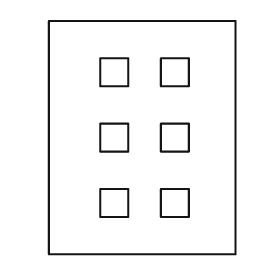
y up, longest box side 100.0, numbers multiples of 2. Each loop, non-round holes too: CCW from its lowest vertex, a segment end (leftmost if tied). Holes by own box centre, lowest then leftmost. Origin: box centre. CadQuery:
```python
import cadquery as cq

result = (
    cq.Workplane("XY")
    .moveTo(-40.0, -50.0)
    .lineTo(40.0, -50.0)
    .lineTo(40.0, 50.0)
    .lineTo(-40.0, 50.0)
    .close()
    .moveTo(-18.0, -34.0)
    .lineTo(-6.0, -34.0)
    .lineTo(-6.0, -22.0)
    .lineTo(-18.0, -22.0)
    .close()
    .moveTo(8.0, -34.0)
    .lineTo(20.0, -34.0)
    .lineTo(20.0, -22.0)
    .lineTo(8.0, -22.0)
    .close()
    .moveTo(-18.0, -6.0)
    .lineTo(-6.0, -6.0)
    .lineTo(-6.0, 6.0)
    .lineTo(-18.0, 6.0)
    .close()
    .moveTo(8.0, -6.0)
    .lineTo(20.0, -6.0)
    .lineTo(20.0, 6.0)
    .lineTo(8.0, 6.0)
    .close()
    .moveTo(-18.0, 22.0)
    .lineTo(-6.0, 22.0)
    .lineTo(-6.0, 34.0)
    .lineTo(-18.0, 34.0)
    .close()
    .moveTo(8.0, 22.0)
    .lineTo(20.0, 22.0)
    .lineTo(20.0, 34.0)
    .lineTo(8.0, 34.0)
    .close()
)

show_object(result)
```